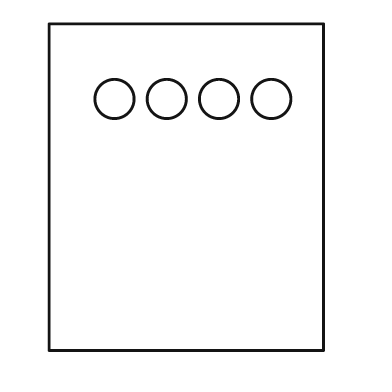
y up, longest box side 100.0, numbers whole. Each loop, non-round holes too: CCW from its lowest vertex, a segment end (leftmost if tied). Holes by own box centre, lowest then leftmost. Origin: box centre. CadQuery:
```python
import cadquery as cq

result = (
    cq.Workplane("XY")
    .moveTo(-42.0, -50.0)
    .lineTo(42.0, -50.0)
    .lineTo(42.0, 50.0)
    .lineTo(-42.0, 50.0)
    .close()
    .moveTo(-22.0, 27.0)
    .circle(6.0)
    .moveTo(-6.0, 27.0)
    .circle(6.0)
    .moveTo(10.0, 27.0)
    .circle(6.0)
    .moveTo(26.0, 27.0)
    .circle(6.0)
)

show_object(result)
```